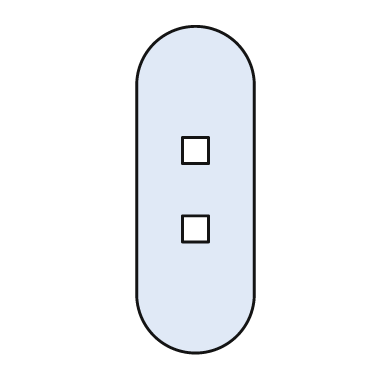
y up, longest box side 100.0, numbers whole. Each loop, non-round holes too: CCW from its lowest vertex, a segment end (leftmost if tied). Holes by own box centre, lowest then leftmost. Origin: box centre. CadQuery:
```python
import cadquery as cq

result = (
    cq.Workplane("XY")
    .moveTo(-18.0, -32.0)
    .threePointArc((0.0, -50.0), (18.0, -32.0))
    .lineTo(18.0, 32.0)
    .threePointArc((0.0, 50.0), (-18.0, 32.0))
    .close()
    .moveTo(-4.0, -16.0)
    .lineTo(4.0, -16.0)
    .lineTo(4.0, -8.0)
    .lineTo(-4.0, -8.0)
    .close()
    .moveTo(-4.0, 8.0)
    .lineTo(4.0, 8.0)
    .lineTo(4.0, 16.0)
    .lineTo(-4.0, 16.0)
    .close()
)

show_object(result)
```